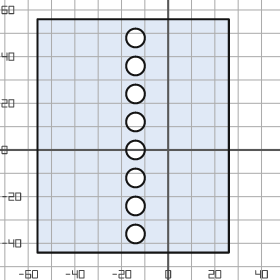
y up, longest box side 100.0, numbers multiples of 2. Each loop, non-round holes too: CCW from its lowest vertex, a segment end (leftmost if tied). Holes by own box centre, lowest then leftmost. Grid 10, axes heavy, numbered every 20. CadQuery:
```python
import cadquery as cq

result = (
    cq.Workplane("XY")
    .moveTo(-56.0, -44.0)
    .lineTo(26.0, -44.0)
    .lineTo(26.0, 56.0)
    .lineTo(-56.0, 56.0)
    .close()
    .moveTo(-14.0, -36.0)
    .circle(4.0)
    .moveTo(-14.0, -24.0)
    .circle(4.0)
    .moveTo(-14.0, -12.0)
    .circle(4.0)
    .moveTo(-14.0, 0.0)
    .circle(4.0)
    .moveTo(-14.0, 12.0)
    .circle(4.0)
    .moveTo(-14.0, 24.0)
    .circle(4.0)
    .moveTo(-14.0, 36.0)
    .circle(4.0)
    .moveTo(-14.0, 48.0)
    .circle(4.0)
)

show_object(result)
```